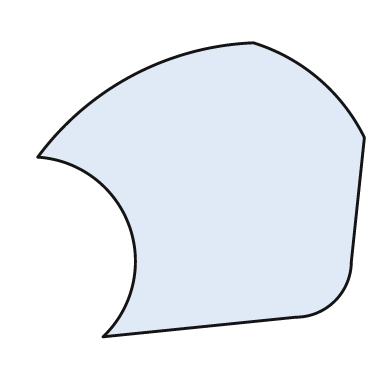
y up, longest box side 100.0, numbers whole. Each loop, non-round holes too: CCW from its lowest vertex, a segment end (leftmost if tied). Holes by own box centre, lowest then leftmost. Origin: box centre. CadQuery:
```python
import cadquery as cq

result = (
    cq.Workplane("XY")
    .moveTo(-30.0, -45.0)
    .lineTo(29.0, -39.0)
    .threePointArc((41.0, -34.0), (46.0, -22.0))
    .lineTo(50.0, 16.0)
    .threePointArc((36.0, 34.0), (16.0, 45.0))
    .threePointArc((-21.0, 35.0), (-50.0, 10.0))
    .threePointArc((-22.0, -11.0), (-30.0, -45.0))
    .close()
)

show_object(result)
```